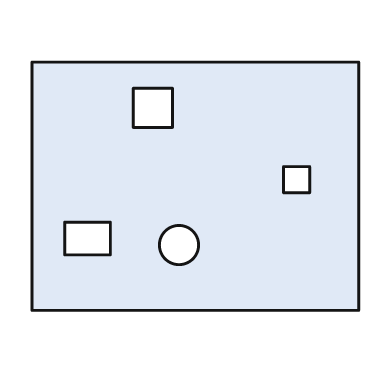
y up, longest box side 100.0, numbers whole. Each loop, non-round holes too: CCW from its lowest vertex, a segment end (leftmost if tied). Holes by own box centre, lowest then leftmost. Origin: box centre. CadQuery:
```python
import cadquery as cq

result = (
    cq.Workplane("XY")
    .moveTo(-50.0, -38.0)
    .lineTo(50.0, -38.0)
    .lineTo(50.0, 38.0)
    .lineTo(-50.0, 38.0)
    .close()
    .moveTo(-5.0, -18.0)
    .circle(6.0)
    .moveTo(-40.0, -21.0)
    .lineTo(-26.0, -21.0)
    .lineTo(-26.0, -11.0)
    .lineTo(-40.0, -11.0)
    .close()
    .moveTo(27.0, -2.0)
    .lineTo(35.0, -2.0)
    .lineTo(35.0, 6.0)
    .lineTo(27.0, 6.0)
    .close()
    .moveTo(-19.0, 18.0)
    .lineTo(-7.0, 18.0)
    .lineTo(-7.0, 30.0)
    .lineTo(-19.0, 30.0)
    .close()
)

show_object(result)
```